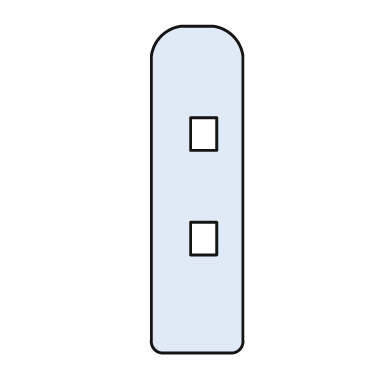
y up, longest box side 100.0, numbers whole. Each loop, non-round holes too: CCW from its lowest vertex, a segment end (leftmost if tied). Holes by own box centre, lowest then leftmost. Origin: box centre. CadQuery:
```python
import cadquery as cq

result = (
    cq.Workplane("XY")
    .moveTo(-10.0, -50.0)
    .lineTo(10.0, -50.0)
    .threePointArc((13.0, -49.0), (14.0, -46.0))
    .lineTo(14.0, 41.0)
    .threePointArc((11.0, 47.0), (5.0, 50.0))
    .lineTo(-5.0, 50.0)
    .threePointArc((-11.0, 47.0), (-14.0, 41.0))
    .lineTo(-14.0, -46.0)
    .threePointArc((-13.0, -49.0), (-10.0, -50.0))
    .close()
    .moveTo(-2.0, -20.0)
    .lineTo(6.0, -20.0)
    .lineTo(6.0, -10.0)
    .lineTo(-2.0, -10.0)
    .close()
    .moveTo(-2.0, 12.0)
    .lineTo(6.0, 12.0)
    .lineTo(6.0, 22.0)
    .lineTo(-2.0, 22.0)
    .close()
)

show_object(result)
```